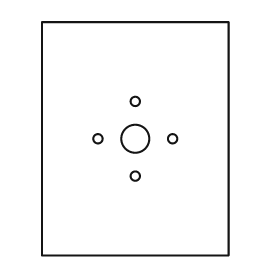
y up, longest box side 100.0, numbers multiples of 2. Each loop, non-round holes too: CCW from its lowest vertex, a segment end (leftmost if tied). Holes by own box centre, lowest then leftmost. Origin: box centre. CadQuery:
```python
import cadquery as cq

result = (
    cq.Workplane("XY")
    .moveTo(-40.0, -50.0)
    .lineTo(40.0, -50.0)
    .lineTo(40.0, 50.0)
    .lineTo(-40.0, 50.0)
    .close()
    .moveTo(0.0, -16.0)
    .circle(2.0)
    .moveTo(-16.0, 0.0)
    .circle(2.0)
    .moveTo(0.0, 0.0)
    .circle(6.0)
    .moveTo(16.0, 0.0)
    .circle(2.0)
    .moveTo(0.0, 16.0)
    .circle(2.0)
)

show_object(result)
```